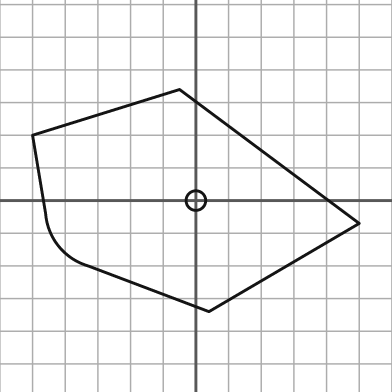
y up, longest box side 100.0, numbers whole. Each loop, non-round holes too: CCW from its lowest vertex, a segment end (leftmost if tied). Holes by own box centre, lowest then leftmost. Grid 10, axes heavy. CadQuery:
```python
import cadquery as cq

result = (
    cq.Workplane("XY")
    .moveTo(4.0, -34.0)
    .lineTo(50.0, -7.0)
    .lineTo(-5.0, 34.0)
    .lineTo(-50.0, 20.0)
    .lineTo(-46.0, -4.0)
    .threePointArc((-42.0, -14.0), (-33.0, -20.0))
    .close()
    .moveTo(0.0, 0.0)
    .circle(3.0)
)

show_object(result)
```